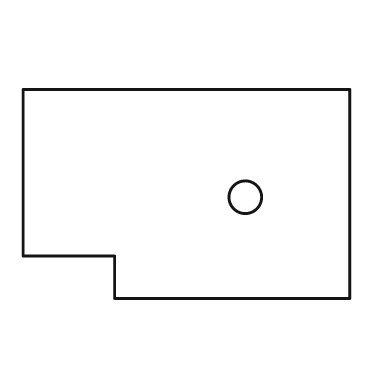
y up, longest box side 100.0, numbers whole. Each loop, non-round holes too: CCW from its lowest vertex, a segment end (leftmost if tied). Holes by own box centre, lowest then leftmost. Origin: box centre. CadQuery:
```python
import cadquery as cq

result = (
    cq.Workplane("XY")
    .moveTo(-22.0, -32.0)
    .lineTo(50.0, -32.0)
    .lineTo(50.0, 32.0)
    .lineTo(-50.0, 32.0)
    .lineTo(-50.0, -19.0)
    .lineTo(-22.0, -19.0)
    .close()
    .moveTo(18.0, -1.0)
    .circle(5.0)
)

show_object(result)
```